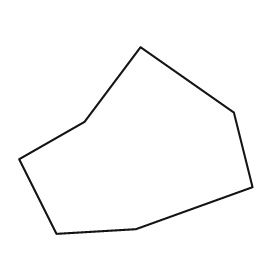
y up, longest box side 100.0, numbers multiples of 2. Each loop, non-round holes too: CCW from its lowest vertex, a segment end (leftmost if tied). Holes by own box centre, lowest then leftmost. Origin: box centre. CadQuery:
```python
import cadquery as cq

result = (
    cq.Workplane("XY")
    .moveTo(-34.0, -40.0)
    .lineTo(0.0, -38.0)
    .lineTo(50.0, -20.0)
    .lineTo(42.0, 12.0)
    .lineTo(2.0, 40.0)
    .lineTo(-22.0, 8.0)
    .lineTo(-50.0, -8.0)
    .close()
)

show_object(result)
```